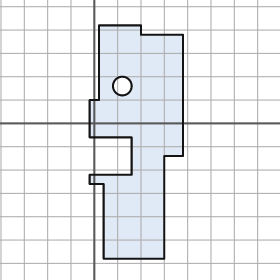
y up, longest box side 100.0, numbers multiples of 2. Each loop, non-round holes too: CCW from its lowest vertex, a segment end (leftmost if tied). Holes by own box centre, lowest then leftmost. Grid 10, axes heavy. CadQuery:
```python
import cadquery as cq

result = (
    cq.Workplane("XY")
    .moveTo(4.0, -58.0)
    .lineTo(30.0, -58.0)
    .lineTo(30.0, -14.0)
    .lineTo(38.0, -14.0)
    .lineTo(38.0, 38.0)
    .lineTo(20.0, 38.0)
    .lineTo(20.0, 42.0)
    .lineTo(2.0, 42.0)
    .lineTo(2.0, 10.0)
    .lineTo(-2.0, 10.0)
    .lineTo(-2.0, -6.0)
    .lineTo(16.0, -6.0)
    .lineTo(16.0, -22.0)
    .lineTo(-2.0, -22.0)
    .lineTo(-2.0, -26.0)
    .lineTo(4.0, -26.0)
    .close()
    .moveTo(12.0, 16.0)
    .circle(4.0)
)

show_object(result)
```